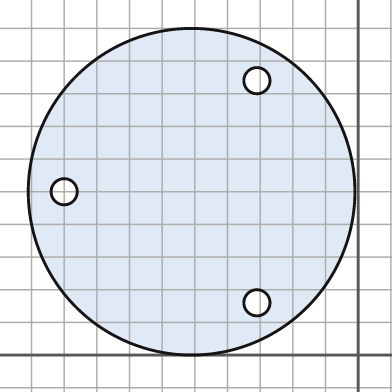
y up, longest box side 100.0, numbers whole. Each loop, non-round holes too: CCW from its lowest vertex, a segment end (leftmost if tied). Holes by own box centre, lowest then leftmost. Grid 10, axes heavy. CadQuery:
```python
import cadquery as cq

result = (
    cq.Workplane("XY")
    .moveTo(-51.0, 50.0)
    .circle(50.0)
    .moveTo(-31.0, 16.0)
    .circle(4.0)
    .moveTo(-90.0, 50.0)
    .circle(4.0)
    .moveTo(-31.0, 84.0)
    .circle(4.0)
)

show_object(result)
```